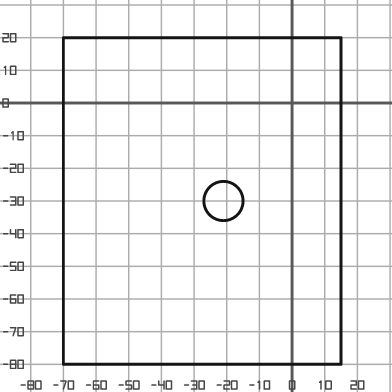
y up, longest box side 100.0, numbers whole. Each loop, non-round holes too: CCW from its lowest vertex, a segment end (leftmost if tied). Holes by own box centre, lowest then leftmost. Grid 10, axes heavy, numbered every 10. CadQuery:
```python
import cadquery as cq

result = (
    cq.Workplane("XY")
    .moveTo(-70.0, -80.0)
    .lineTo(15.0, -80.0)
    .lineTo(15.0, 20.0)
    .lineTo(-70.0, 20.0)
    .close()
    .moveTo(-21.0, -30.0)
    .circle(6.0)
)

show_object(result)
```